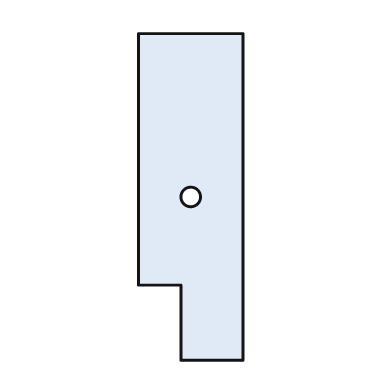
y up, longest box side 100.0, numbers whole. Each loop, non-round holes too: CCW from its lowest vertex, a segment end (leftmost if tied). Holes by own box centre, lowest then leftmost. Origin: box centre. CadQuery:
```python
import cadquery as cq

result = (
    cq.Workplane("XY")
    .moveTo(-3.0, -50.0)
    .lineTo(16.0, -50.0)
    .lineTo(16.0, 50.0)
    .lineTo(-16.0, 50.0)
    .lineTo(-16.0, -27.0)
    .lineTo(-3.0, -27.0)
    .close()
    .moveTo(0.0, 0.0)
    .circle(3.0)
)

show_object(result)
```